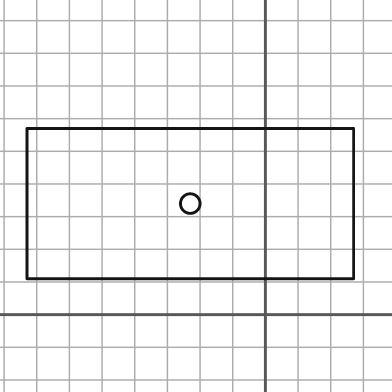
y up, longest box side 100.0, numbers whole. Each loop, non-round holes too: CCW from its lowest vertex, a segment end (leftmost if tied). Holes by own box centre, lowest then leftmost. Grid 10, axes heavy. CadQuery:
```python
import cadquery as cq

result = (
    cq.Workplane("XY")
    .moveTo(-73.0, 11.0)
    .lineTo(27.0, 11.0)
    .lineTo(27.0, 57.0)
    .lineTo(-73.0, 57.0)
    .close()
    .moveTo(-23.0, 34.0)
    .circle(3.0)
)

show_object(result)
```